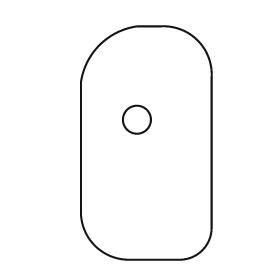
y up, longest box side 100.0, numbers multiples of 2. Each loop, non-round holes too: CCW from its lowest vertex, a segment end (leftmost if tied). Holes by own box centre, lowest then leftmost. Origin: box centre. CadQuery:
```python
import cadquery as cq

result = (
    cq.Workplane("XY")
    .moveTo(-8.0, -50.0)
    .lineTo(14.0, -50.0)
    .threePointArc((24.0, -46.0), (28.0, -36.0))
    .lineTo(28.0, 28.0)
    .threePointArc((22.0, 44.0), (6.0, 50.0))
    .lineTo(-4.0, 50.0)
    .threePointArc((-20.0, 42.0), (-28.0, 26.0))
    .lineTo(-28.0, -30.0)
    .threePointArc((-22.0, -44.0), (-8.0, -50.0))
    .close()
    .moveTo(-4.0, 10.0)
    .circle(6.0)
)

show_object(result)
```